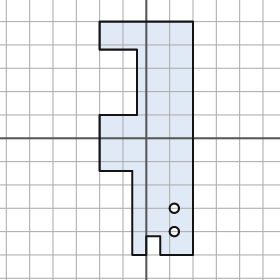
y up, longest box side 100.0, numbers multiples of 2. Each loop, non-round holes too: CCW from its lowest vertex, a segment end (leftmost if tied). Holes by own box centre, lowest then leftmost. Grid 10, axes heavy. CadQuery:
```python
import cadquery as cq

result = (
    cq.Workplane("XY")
    .moveTo(-6.0, -50.0)
    .lineTo(0.0, -50.0)
    .lineTo(0.0, -42.0)
    .lineTo(6.0, -42.0)
    .lineTo(6.0, -50.0)
    .lineTo(20.0, -50.0)
    .lineTo(20.0, 50.0)
    .lineTo(-20.0, 50.0)
    .lineTo(-20.0, 38.0)
    .lineTo(-4.0, 38.0)
    .lineTo(-4.0, 10.0)
    .lineTo(-20.0, 10.0)
    .lineTo(-20.0, -14.0)
    .lineTo(-6.0, -14.0)
    .close()
    .moveTo(12.0, -40.0)
    .circle(2.0)
    .moveTo(12.0, -30.0)
    .circle(2.0)
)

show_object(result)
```